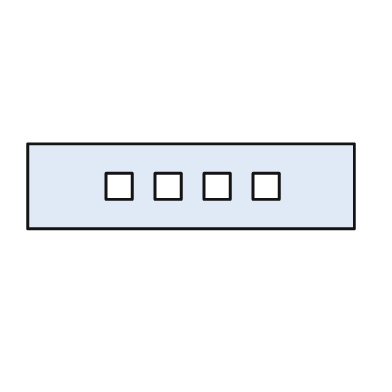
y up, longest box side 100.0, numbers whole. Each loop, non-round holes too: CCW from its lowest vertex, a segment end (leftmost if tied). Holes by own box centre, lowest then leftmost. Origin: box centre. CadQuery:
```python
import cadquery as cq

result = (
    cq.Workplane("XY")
    .moveTo(-50.0, -13.0)
    .lineTo(50.0, -13.0)
    .lineTo(50.0, 13.0)
    .lineTo(-50.0, 13.0)
    .close()
    .moveTo(-26.0, -4.0)
    .lineTo(-18.0, -4.0)
    .lineTo(-18.0, 4.0)
    .lineTo(-26.0, 4.0)
    .close()
    .moveTo(-11.0, -4.0)
    .lineTo(-3.0, -4.0)
    .lineTo(-3.0, 4.0)
    .lineTo(-11.0, 4.0)
    .close()
    .moveTo(4.0, -4.0)
    .lineTo(12.0, -4.0)
    .lineTo(12.0, 4.0)
    .lineTo(4.0, 4.0)
    .close()
    .moveTo(19.0, -4.0)
    .lineTo(27.0, -4.0)
    .lineTo(27.0, 4.0)
    .lineTo(19.0, 4.0)
    .close()
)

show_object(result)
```